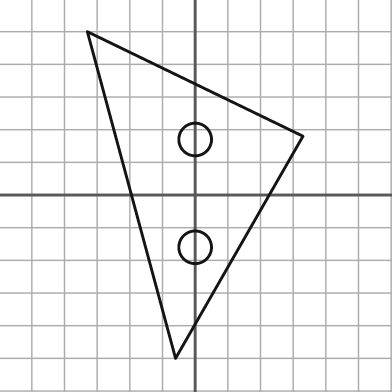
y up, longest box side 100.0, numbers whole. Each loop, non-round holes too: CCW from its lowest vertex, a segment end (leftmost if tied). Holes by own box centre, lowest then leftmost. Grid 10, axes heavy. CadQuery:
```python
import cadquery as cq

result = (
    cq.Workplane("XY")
    .moveTo(-6.0, -50.0)
    .lineTo(33.0, 18.0)
    .lineTo(-33.0, 50.0)
    .close()
    .moveTo(0.0, -16.0)
    .circle(5.0)
    .moveTo(0.0, 17.0)
    .circle(5.0)
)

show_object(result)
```